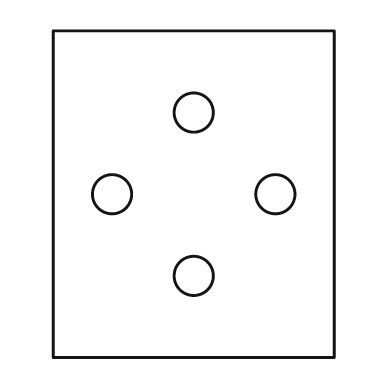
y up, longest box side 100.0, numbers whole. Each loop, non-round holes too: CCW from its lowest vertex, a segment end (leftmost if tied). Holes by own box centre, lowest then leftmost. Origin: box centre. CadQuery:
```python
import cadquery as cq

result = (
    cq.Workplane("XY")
    .moveTo(-43.0, -50.0)
    .lineTo(43.0, -50.0)
    .lineTo(43.0, 50.0)
    .lineTo(-43.0, 50.0)
    .close()
    .moveTo(0.0, -25.0)
    .circle(6.0)
    .moveTo(-25.0, 0.0)
    .circle(6.0)
    .moveTo(25.0, 0.0)
    .circle(6.0)
    .moveTo(0.0, 25.0)
    .circle(6.0)
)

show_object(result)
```